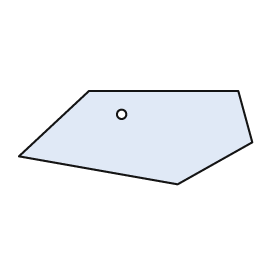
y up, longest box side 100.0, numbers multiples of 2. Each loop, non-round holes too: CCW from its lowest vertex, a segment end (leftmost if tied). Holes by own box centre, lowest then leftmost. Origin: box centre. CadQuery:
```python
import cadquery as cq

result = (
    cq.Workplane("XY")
    .moveTo(18.0, -20.0)
    .lineTo(50.0, -2.0)
    .lineTo(44.0, 20.0)
    .lineTo(-20.0, 20.0)
    .lineTo(-50.0, -8.0)
    .close()
    .moveTo(-6.0, 10.0)
    .circle(2.0)
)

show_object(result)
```